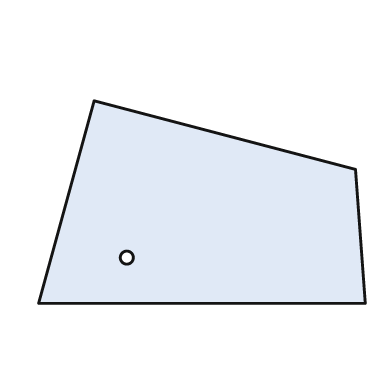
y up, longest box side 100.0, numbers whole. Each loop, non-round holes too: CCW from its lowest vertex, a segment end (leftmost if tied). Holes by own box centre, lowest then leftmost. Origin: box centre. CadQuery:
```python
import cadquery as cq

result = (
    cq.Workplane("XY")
    .moveTo(-50.0, -31.0)
    .lineTo(50.0, -31.0)
    .lineTo(47.0, 10.0)
    .lineTo(-33.0, 31.0)
    .close()
    .moveTo(-23.0, -17.0)
    .circle(2.0)
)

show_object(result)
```